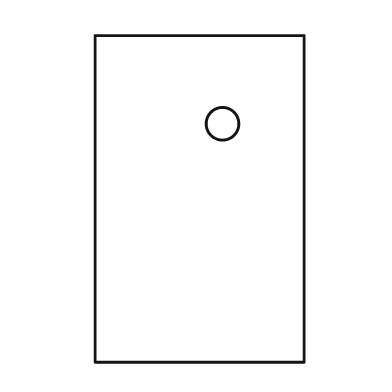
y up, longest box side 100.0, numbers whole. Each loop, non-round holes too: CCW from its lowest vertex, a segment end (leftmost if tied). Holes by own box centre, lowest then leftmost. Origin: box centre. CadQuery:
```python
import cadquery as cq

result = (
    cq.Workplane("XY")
    .moveTo(-32.0, -50.0)
    .lineTo(32.0, -50.0)
    .lineTo(32.0, 50.0)
    .lineTo(-32.0, 50.0)
    .close()
    .moveTo(7.0, 23.0)
    .circle(5.0)
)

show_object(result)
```